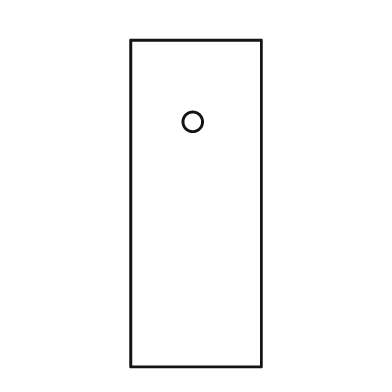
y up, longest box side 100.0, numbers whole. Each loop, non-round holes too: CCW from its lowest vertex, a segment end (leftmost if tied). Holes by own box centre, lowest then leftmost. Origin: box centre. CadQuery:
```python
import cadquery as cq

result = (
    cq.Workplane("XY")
    .moveTo(-20.0, -50.0)
    .lineTo(20.0, -50.0)
    .lineTo(20.0, 50.0)
    .lineTo(-20.0, 50.0)
    .close()
    .moveTo(-1.0, 25.0)
    .circle(3.0)
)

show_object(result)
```